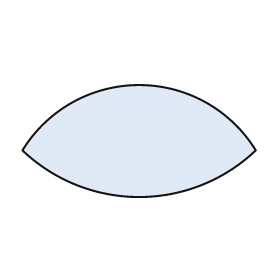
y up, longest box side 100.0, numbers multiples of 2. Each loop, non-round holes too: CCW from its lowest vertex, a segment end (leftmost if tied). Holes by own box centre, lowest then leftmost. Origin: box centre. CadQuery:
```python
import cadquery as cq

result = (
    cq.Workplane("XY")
    .moveTo(-50.0, -4.0)
    .threePointArc((0.0, -24.0), (50.0, -4.0))
    .threePointArc((0.0, 24.0), (-50.0, -4.0))
    .close()
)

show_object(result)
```